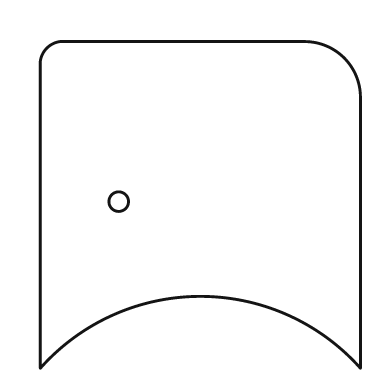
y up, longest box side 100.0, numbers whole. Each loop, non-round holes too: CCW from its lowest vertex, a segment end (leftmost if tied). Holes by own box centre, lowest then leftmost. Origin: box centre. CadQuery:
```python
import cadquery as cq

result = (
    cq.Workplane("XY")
    .moveTo(-49.0, -50.0)
    .threePointArc((0.0, -28.0), (49.0, -50.0))
    .lineTo(49.0, 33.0)
    .threePointArc((44.0, 45.0), (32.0, 50.0))
    .lineTo(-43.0, 50.0)
    .threePointArc((-47.0, 48.0), (-49.0, 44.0))
    .close()
    .moveTo(-25.0, 1.0)
    .circle(3.0)
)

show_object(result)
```